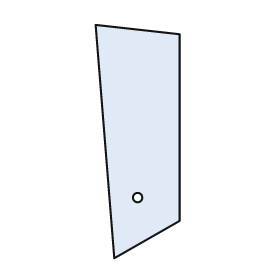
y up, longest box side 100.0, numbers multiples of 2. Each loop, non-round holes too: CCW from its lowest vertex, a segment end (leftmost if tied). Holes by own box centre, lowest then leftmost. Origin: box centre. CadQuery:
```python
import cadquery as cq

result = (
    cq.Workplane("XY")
    .moveTo(-10.0, -50.0)
    .lineTo(18.0, -34.0)
    .lineTo(18.0, 46.0)
    .lineTo(-18.0, 50.0)
    .close()
    .moveTo(0.0, -24.0)
    .circle(2.0)
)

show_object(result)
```